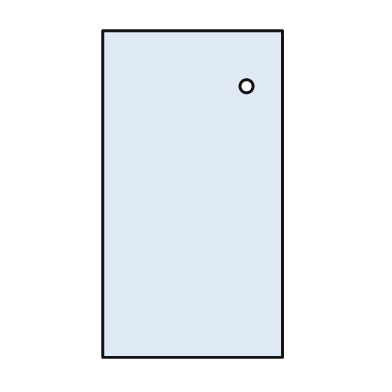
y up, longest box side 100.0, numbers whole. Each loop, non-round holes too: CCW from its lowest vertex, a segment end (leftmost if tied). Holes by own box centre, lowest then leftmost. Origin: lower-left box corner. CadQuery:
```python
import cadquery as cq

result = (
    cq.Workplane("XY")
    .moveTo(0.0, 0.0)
    .lineTo(55.0, 0.0)
    .lineTo(55.0, 100.0)
    .lineTo(0.0, 100.0)
    .close()
    .moveTo(44.0, 83.0)
    .circle(2.0)
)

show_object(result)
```